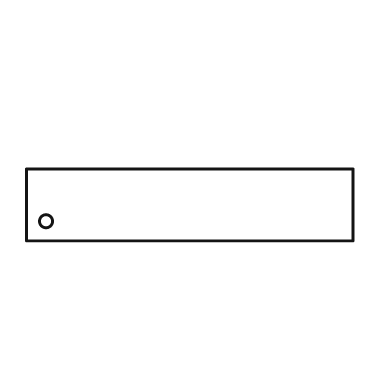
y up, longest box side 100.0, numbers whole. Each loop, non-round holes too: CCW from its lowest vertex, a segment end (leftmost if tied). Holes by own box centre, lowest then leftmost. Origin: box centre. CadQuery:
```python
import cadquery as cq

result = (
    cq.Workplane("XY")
    .moveTo(-50.0, -11.0)
    .lineTo(50.0, -11.0)
    .lineTo(50.0, 11.0)
    .lineTo(-50.0, 11.0)
    .close()
    .moveTo(-44.0, -5.0)
    .circle(2.0)
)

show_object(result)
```